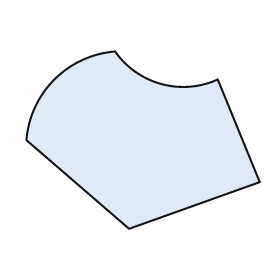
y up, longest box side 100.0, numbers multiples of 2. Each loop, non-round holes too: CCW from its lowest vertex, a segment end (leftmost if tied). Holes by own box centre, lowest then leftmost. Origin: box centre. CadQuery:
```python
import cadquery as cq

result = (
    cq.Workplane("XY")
    .moveTo(-6.0, -38.0)
    .lineTo(50.0, -18.0)
    .lineTo(32.0, 26.0)
    .threePointArc((8.0, 24.0), (-12.0, 38.0))
    .threePointArc((-38.0, 26.0), (-50.0, 0.0))
    .close()
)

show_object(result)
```